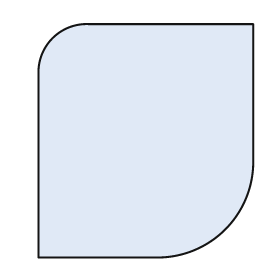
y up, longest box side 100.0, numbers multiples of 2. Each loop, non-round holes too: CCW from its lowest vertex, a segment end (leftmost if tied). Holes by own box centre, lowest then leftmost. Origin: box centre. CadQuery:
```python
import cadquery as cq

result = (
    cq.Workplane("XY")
    .moveTo(-46.0, -50.0)
    .lineTo(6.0, -50.0)
    .threePointArc((34.0, -38.0), (46.0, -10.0))
    .lineTo(46.0, 50.0)
    .lineTo(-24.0, 50.0)
    .threePointArc((-40.0, 44.0), (-46.0, 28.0))
    .close()
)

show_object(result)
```